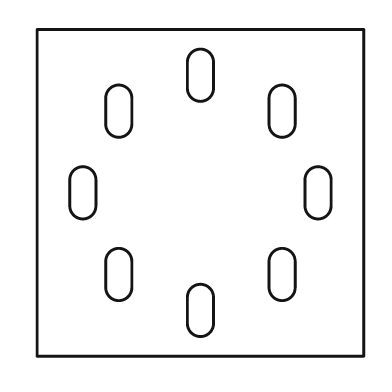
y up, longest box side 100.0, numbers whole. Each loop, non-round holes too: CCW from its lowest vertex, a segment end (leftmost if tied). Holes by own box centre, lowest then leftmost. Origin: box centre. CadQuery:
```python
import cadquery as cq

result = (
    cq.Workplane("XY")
    .moveTo(-50.0, -50.0)
    .lineTo(50.0, -50.0)
    .lineTo(50.0, 50.0)
    .lineTo(-50.0, 50.0)
    .close()
    .moveTo(-4.0, -40.0)
    .threePointArc((0.0, -44.0), (4.0, -40.0))
    .lineTo(4.0, -32.0)
    .threePointArc((0.0, -28.0), (-4.0, -32.0))
    .close()
    .moveTo(-29.0, -29.0)
    .threePointArc((-25.0, -33.0), (-21.0, -29.0))
    .lineTo(-21.0, -21.0)
    .threePointArc((-25.0, -17.0), (-29.0, -21.0))
    .close()
    .moveTo(21.0, -29.0)
    .threePointArc((25.0, -33.0), (29.0, -29.0))
    .lineTo(29.0, -21.0)
    .threePointArc((25.0, -17.0), (21.0, -21.0))
    .close()
    .moveTo(-40.0, -4.0)
    .threePointArc((-36.0, -8.0), (-32.0, -4.0))
    .lineTo(-32.0, 4.0)
    .threePointArc((-36.0, 8.0), (-40.0, 4.0))
    .close()
    .moveTo(32.0, -4.0)
    .threePointArc((36.0, -8.0), (40.0, -4.0))
    .lineTo(40.0, 4.0)
    .threePointArc((36.0, 8.0), (32.0, 4.0))
    .close()
    .moveTo(-29.0, 21.0)
    .threePointArc((-25.0, 17.0), (-21.0, 21.0))
    .lineTo(-21.0, 29.0)
    .threePointArc((-25.0, 33.0), (-29.0, 29.0))
    .close()
    .moveTo(21.0, 21.0)
    .threePointArc((25.0, 17.0), (29.0, 21.0))
    .lineTo(29.0, 29.0)
    .threePointArc((25.0, 33.0), (21.0, 29.0))
    .close()
    .moveTo(-4.0, 32.0)
    .threePointArc((0.0, 28.0), (4.0, 32.0))
    .lineTo(4.0, 40.0)
    .threePointArc((0.0, 44.0), (-4.0, 40.0))
    .close()
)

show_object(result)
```